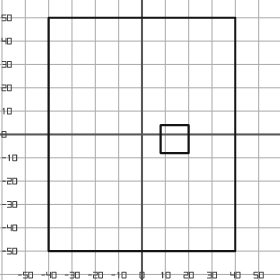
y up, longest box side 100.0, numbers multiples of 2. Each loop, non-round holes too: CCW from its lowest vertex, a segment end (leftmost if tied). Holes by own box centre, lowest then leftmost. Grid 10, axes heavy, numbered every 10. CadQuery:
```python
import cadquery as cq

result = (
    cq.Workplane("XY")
    .moveTo(-40.0, -50.0)
    .lineTo(40.0, -50.0)
    .lineTo(40.0, 50.0)
    .lineTo(-40.0, 50.0)
    .close()
    .moveTo(8.0, -8.0)
    .lineTo(20.0, -8.0)
    .lineTo(20.0, 4.0)
    .lineTo(8.0, 4.0)
    .close()
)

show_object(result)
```